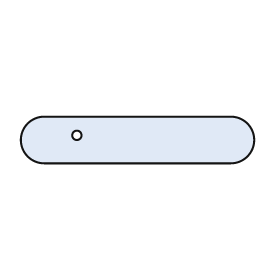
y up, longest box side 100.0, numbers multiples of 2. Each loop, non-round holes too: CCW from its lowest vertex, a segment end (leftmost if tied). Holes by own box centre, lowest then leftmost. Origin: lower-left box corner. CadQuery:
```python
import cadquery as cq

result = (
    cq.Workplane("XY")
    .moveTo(10.0, 0.0)
    .lineTo(90.0, 0.0)
    .threePointArc((100.0, 10.0), (90.0, 20.0))
    .lineTo(10.0, 20.0)
    .threePointArc((0.0, 10.0), (10.0, 0.0))
    .close()
    .moveTo(24.0, 12.0)
    .circle(2.0)
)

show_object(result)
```